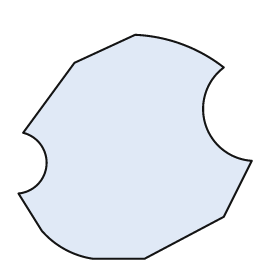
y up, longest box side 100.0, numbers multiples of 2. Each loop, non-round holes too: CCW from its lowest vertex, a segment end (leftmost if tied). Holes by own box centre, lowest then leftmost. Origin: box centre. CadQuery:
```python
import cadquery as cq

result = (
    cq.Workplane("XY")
    .moveTo(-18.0, -48.0)
    .lineTo(4.0, -48.0)
    .lineTo(38.0, -30.0)
    .lineTo(50.0, -6.0)
    .threePointArc((30.0, 10.0), (38.0, 34.0))
    .threePointArc((20.0, 44.0), (0.0, 48.0))
    .lineTo(-26.0, 36.0)
    .lineTo(-48.0, 6.0)
    .threePointArc((-38.0, -8.0), (-50.0, -20.0))
    .lineTo(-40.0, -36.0)
    .threePointArc((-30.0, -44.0), (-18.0, -48.0))
    .close()
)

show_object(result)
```